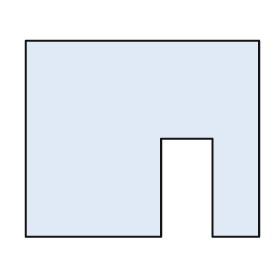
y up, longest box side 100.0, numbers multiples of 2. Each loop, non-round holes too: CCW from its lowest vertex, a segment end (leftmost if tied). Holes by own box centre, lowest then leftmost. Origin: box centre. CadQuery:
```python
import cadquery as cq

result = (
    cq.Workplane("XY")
    .moveTo(-50.0, -42.0)
    .lineTo(8.0, -42.0)
    .lineTo(8.0, 0.0)
    .lineTo(30.0, 0.0)
    .lineTo(30.0, -42.0)
    .lineTo(50.0, -42.0)
    .lineTo(50.0, 42.0)
    .lineTo(-50.0, 42.0)
    .close()
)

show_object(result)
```